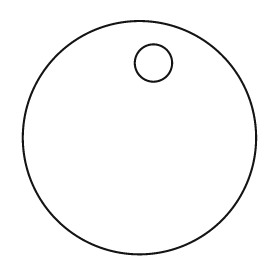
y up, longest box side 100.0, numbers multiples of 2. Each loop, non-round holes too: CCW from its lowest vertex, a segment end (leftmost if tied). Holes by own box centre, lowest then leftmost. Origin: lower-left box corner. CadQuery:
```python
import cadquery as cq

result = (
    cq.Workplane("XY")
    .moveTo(50.0, 50.0)
    .circle(50.0)
    .moveTo(56.0, 82.0)
    .circle(8.0)
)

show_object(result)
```